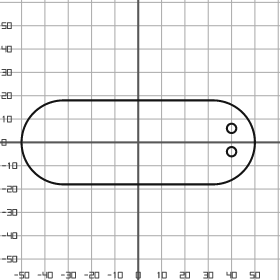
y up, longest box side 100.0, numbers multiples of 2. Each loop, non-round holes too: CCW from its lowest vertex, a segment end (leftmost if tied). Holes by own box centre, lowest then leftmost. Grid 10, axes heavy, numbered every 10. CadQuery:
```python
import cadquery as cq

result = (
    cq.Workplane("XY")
    .moveTo(-32.0, -18.0)
    .lineTo(32.0, -18.0)
    .threePointArc((50.0, 0.0), (32.0, 18.0))
    .lineTo(-32.0, 18.0)
    .threePointArc((-50.0, 0.0), (-32.0, -18.0))
    .close()
    .moveTo(40.0, -4.0)
    .circle(2.0)
    .moveTo(40.0, 6.0)
    .circle(2.0)
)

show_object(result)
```